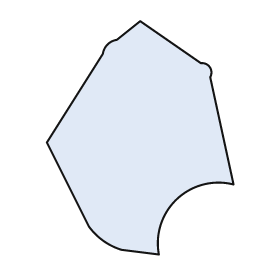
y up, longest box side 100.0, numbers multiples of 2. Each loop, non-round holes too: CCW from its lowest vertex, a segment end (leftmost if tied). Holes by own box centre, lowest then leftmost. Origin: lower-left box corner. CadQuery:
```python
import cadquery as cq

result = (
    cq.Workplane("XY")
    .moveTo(48.0, 0.0)
    .threePointArc((56.0, 24.0), (80.0, 30.0))
    .lineTo(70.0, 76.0)
    .threePointArc((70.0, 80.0), (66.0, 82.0))
    .lineTo(40.0, 100.0)
    .lineTo(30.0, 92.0)
    .threePointArc((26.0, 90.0), (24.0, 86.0))
    .lineTo(0.0, 48.0)
    .lineTo(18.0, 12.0)
    .threePointArc((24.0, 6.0), (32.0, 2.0))
    .close()
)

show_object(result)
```